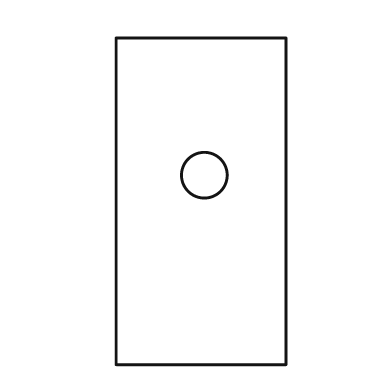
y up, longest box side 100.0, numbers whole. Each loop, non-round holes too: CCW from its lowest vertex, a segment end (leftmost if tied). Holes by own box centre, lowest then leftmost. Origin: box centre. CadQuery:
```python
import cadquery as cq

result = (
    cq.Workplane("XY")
    .moveTo(-26.0, -50.0)
    .lineTo(26.0, -50.0)
    .lineTo(26.0, 50.0)
    .lineTo(-26.0, 50.0)
    .close()
    .moveTo(1.0, 8.0)
    .circle(7.0)
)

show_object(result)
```